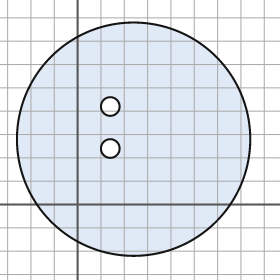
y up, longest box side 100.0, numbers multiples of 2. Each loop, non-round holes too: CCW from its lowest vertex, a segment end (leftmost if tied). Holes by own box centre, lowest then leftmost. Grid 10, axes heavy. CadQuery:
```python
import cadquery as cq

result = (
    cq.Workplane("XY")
    .moveTo(24.0, 28.0)
    .circle(50.0)
    .moveTo(14.0, 24.0)
    .circle(4.0)
    .moveTo(14.0, 42.0)
    .circle(4.0)
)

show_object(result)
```